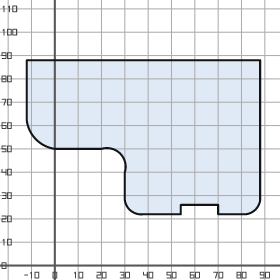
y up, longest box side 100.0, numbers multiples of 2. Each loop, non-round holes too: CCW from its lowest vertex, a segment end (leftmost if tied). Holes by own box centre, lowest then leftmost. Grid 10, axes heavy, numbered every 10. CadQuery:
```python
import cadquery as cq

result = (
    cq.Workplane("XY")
    .moveTo(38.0, 22.0)
    .lineTo(54.0, 22.0)
    .lineTo(54.0, 26.0)
    .lineTo(70.0, 26.0)
    .lineTo(70.0, 22.0)
    .lineTo(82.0, 22.0)
    .threePointArc((86.0, 24.0), (88.0, 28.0))
    .lineTo(88.0, 88.0)
    .lineTo(-12.0, 88.0)
    .lineTo(-12.0, 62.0)
    .threePointArc((-8.0, 54.0), (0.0, 50.0))
    .lineTo(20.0, 50.0)
    .threePointArc((28.0, 48.0), (30.0, 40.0))
    .lineTo(30.0, 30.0)
    .threePointArc((32.0, 24.0), (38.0, 22.0))
    .close()
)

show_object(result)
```